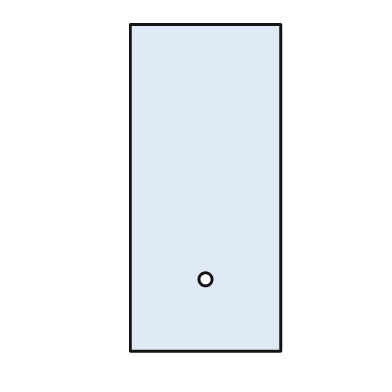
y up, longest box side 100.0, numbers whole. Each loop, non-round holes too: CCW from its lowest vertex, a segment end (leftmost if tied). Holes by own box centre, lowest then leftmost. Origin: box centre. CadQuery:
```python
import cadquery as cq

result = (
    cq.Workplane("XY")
    .moveTo(-23.0, -50.0)
    .lineTo(23.0, -50.0)
    .lineTo(23.0, 50.0)
    .lineTo(-23.0, 50.0)
    .close()
    .moveTo(0.0, -28.0)
    .circle(2.0)
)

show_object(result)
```